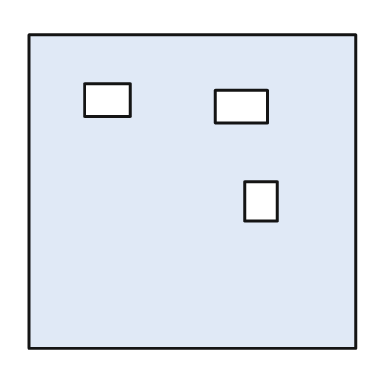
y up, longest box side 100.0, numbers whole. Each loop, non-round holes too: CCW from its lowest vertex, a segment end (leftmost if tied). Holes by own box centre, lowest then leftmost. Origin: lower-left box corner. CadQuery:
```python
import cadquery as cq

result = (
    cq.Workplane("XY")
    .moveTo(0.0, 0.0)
    .lineTo(100.0, 0.0)
    .lineTo(100.0, 96.0)
    .lineTo(0.0, 96.0)
    .close()
    .moveTo(66.0, 39.0)
    .lineTo(76.0, 39.0)
    .lineTo(76.0, 51.0)
    .lineTo(66.0, 51.0)
    .close()
    .moveTo(57.0, 69.0)
    .lineTo(73.0, 69.0)
    .lineTo(73.0, 79.0)
    .lineTo(57.0, 79.0)
    .close()
    .moveTo(17.0, 71.0)
    .lineTo(31.0, 71.0)
    .lineTo(31.0, 81.0)
    .lineTo(17.0, 81.0)
    .close()
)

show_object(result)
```